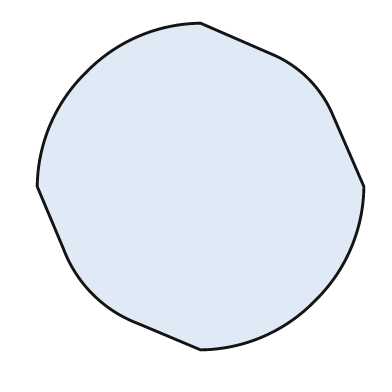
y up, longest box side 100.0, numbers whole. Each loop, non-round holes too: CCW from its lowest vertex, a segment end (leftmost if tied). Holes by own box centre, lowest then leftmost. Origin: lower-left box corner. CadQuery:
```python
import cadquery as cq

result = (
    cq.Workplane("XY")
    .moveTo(50.0, 0.0)
    .threePointArc((69.0, 4.0), (85.0, 15.0))
    .threePointArc((96.0, 31.0), (100.0, 50.0))
    .lineTo(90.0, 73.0)
    .threePointArc((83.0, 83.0), (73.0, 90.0))
    .lineTo(50.0, 100.0)
    .threePointArc((31.0, 96.0), (15.0, 85.0))
    .threePointArc((4.0, 69.0), (0.0, 50.0))
    .lineTo(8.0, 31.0)
    .threePointArc((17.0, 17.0), (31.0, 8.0))
    .close()
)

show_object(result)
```